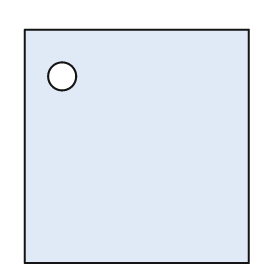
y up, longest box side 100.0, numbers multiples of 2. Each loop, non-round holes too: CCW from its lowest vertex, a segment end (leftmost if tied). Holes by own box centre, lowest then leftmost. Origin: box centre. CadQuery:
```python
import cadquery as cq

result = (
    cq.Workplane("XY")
    .moveTo(-48.0, -50.0)
    .lineTo(48.0, -50.0)
    .lineTo(48.0, 50.0)
    .lineTo(-48.0, 50.0)
    .close()
    .moveTo(-32.0, 30.0)
    .circle(6.0)
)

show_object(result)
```